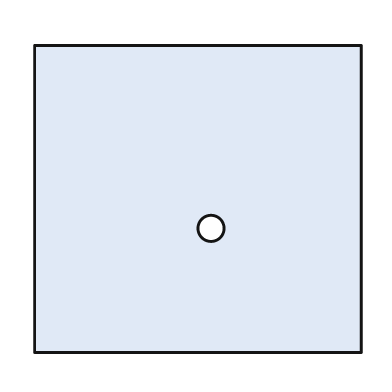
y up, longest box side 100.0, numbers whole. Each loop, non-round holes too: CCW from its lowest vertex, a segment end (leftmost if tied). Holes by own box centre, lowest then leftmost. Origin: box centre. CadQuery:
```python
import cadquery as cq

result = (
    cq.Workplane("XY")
    .moveTo(-50.0, -47.0)
    .lineTo(50.0, -47.0)
    .lineTo(50.0, 47.0)
    .lineTo(-50.0, 47.0)
    .close()
    .moveTo(4.0, -9.0)
    .circle(4.0)
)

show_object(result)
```